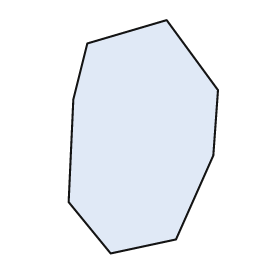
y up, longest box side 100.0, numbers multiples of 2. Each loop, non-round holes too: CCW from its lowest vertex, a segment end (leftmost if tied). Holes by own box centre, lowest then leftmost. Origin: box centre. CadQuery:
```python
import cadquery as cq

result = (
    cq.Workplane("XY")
    .moveTo(-14.0, -50.0)
    .lineTo(14.0, -44.0)
    .lineTo(30.0, -8.0)
    .lineTo(32.0, 20.0)
    .lineTo(10.0, 50.0)
    .lineTo(-24.0, 40.0)
    .lineTo(-30.0, 16.0)
    .lineTo(-32.0, -28.0)
    .close()
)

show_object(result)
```